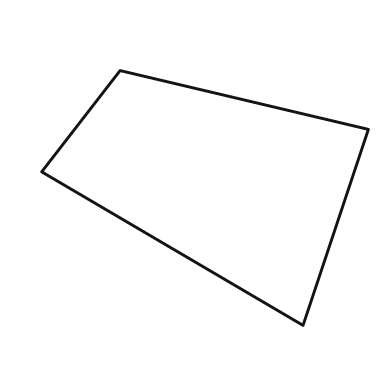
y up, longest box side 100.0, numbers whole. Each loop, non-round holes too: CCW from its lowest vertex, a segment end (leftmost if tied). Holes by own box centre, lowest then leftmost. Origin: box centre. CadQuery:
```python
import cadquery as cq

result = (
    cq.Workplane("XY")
    .moveTo(30.0, -39.0)
    .lineTo(50.0, 21.0)
    .lineTo(-26.0, 39.0)
    .lineTo(-50.0, 8.0)
    .close()
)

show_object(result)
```